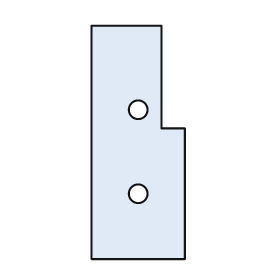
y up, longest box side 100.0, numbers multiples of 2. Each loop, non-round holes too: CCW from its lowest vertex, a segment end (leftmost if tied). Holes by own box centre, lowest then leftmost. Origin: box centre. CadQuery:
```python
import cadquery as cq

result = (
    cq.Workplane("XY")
    .moveTo(-20.0, -50.0)
    .lineTo(20.0, -50.0)
    .lineTo(20.0, 6.0)
    .lineTo(10.0, 6.0)
    .lineTo(10.0, 50.0)
    .lineTo(-20.0, 50.0)
    .close()
    .moveTo(0.0, -22.0)
    .circle(4.0)
    .moveTo(0.0, 14.0)
    .circle(4.0)
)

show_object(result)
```